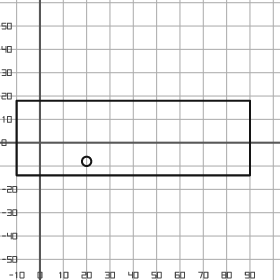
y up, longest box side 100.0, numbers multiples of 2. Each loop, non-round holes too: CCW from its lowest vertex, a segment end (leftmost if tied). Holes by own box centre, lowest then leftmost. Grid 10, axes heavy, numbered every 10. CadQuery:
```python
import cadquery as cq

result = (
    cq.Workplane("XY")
    .moveTo(-10.0, -14.0)
    .lineTo(90.0, -14.0)
    .lineTo(90.0, 18.0)
    .lineTo(-10.0, 18.0)
    .close()
    .moveTo(20.0, -8.0)
    .circle(2.0)
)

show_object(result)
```